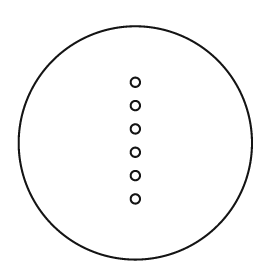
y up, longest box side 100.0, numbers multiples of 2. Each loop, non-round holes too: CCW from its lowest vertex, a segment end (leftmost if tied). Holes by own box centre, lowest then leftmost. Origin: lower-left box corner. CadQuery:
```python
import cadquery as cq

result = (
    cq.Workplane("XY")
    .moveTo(50.0, 50.0)
    .circle(50.0)
    .moveTo(50.0, 26.0)
    .circle(2.0)
    .moveTo(50.0, 36.0)
    .circle(2.0)
    .moveTo(50.0, 46.0)
    .circle(2.0)
    .moveTo(50.0, 56.0)
    .circle(2.0)
    .moveTo(50.0, 66.0)
    .circle(2.0)
    .moveTo(50.0, 76.0)
    .circle(2.0)
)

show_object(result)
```